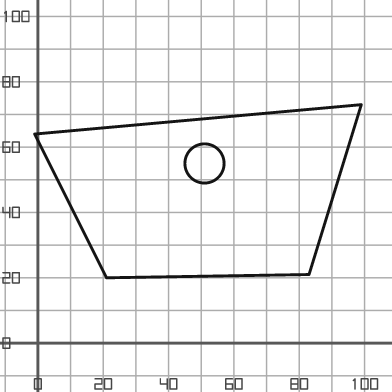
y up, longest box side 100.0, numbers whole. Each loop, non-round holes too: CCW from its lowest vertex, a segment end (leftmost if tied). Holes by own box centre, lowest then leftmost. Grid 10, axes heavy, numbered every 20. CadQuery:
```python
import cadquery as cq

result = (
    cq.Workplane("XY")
    .moveTo(21.0, 20.0)
    .lineTo(83.0, 21.0)
    .lineTo(99.0, 73.0)
    .lineTo(-1.0, 64.0)
    .close()
    .moveTo(51.0, 55.0)
    .circle(6.0)
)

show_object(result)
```